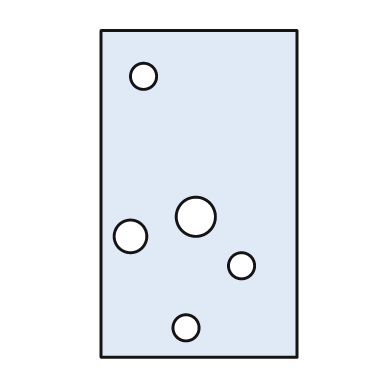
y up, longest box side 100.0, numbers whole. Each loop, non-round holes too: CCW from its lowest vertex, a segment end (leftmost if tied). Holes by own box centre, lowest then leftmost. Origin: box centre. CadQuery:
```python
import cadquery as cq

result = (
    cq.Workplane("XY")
    .moveTo(-30.0, -50.0)
    .lineTo(30.0, -50.0)
    .lineTo(30.0, 50.0)
    .lineTo(-30.0, 50.0)
    .close()
    .moveTo(-4.0, -41.0)
    .circle(4.0)
    .moveTo(13.0, -22.0)
    .circle(4.0)
    .moveTo(-21.0, -13.0)
    .circle(5.0)
    .moveTo(-1.0, -7.0)
    .circle(6.0)
    .moveTo(-17.0, 36.0)
    .circle(4.0)
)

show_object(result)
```